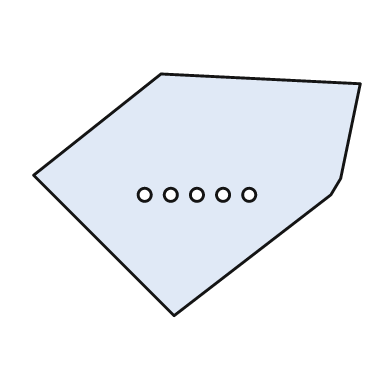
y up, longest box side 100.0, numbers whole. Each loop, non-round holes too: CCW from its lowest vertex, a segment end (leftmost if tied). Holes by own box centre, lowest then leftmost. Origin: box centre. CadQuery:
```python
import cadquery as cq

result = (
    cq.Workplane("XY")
    .moveTo(-7.0, -37.0)
    .lineTo(41.0, 0.0)
    .lineTo(44.0, 5.0)
    .lineTo(50.0, 34.0)
    .lineTo(-11.0, 37.0)
    .lineTo(-50.0, 6.0)
    .close()
    .moveTo(-16.0, 0.0)
    .circle(2.0)
    .moveTo(-8.0, 0.0)
    .circle(2.0)
    .moveTo(0.0, 0.0)
    .circle(2.0)
    .moveTo(8.0, 0.0)
    .circle(2.0)
    .moveTo(16.0, 0.0)
    .circle(2.0)
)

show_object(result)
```